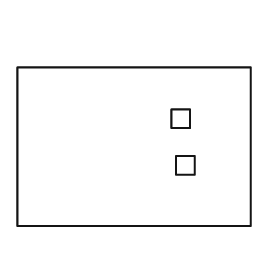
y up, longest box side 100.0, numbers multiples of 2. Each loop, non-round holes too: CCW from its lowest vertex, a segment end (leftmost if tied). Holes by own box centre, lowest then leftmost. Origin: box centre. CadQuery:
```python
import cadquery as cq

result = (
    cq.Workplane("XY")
    .moveTo(-50.0, -34.0)
    .lineTo(50.0, -34.0)
    .lineTo(50.0, 34.0)
    .lineTo(-50.0, 34.0)
    .close()
    .moveTo(18.0, -12.0)
    .lineTo(26.0, -12.0)
    .lineTo(26.0, -4.0)
    .lineTo(18.0, -4.0)
    .close()
    .moveTo(16.0, 8.0)
    .lineTo(24.0, 8.0)
    .lineTo(24.0, 16.0)
    .lineTo(16.0, 16.0)
    .close()
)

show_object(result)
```